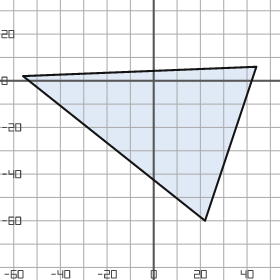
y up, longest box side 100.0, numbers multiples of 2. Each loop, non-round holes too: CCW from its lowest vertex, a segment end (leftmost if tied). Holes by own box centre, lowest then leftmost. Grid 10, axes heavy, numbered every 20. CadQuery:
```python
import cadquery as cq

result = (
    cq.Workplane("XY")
    .moveTo(22.0, -60.0)
    .lineTo(44.0, 6.0)
    .lineTo(-56.0, 2.0)
    .close()
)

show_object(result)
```